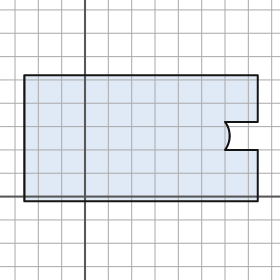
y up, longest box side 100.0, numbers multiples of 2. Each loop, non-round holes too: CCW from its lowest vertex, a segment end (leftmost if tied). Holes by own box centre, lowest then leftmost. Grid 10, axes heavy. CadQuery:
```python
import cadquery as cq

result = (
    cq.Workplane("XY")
    .moveTo(-26.0, -2.0)
    .lineTo(74.0, -2.0)
    .lineTo(74.0, 20.0)
    .lineTo(60.0, 20.0)
    .threePointArc((62.0, 26.0), (60.0, 32.0))
    .lineTo(74.0, 32.0)
    .lineTo(74.0, 52.0)
    .lineTo(-26.0, 52.0)
    .close()
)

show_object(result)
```